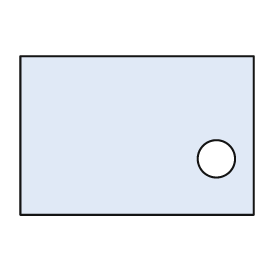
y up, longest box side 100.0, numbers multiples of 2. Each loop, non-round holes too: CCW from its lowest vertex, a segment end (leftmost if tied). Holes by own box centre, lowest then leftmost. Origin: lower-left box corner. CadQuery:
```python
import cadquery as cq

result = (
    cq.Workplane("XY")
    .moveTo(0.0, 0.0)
    .lineTo(100.0, 0.0)
    .lineTo(100.0, 68.0)
    .lineTo(0.0, 68.0)
    .close()
    .moveTo(84.0, 24.0)
    .circle(8.0)
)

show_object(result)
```